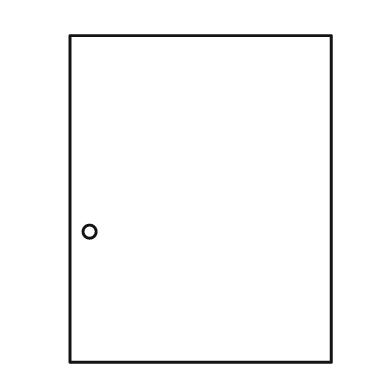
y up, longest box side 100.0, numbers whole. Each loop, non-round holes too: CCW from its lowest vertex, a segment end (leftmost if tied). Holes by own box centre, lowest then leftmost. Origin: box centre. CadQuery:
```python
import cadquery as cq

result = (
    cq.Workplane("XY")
    .moveTo(-40.0, -50.0)
    .lineTo(40.0, -50.0)
    .lineTo(40.0, 50.0)
    .lineTo(-40.0, 50.0)
    .close()
    .moveTo(-34.0, -10.0)
    .circle(2.0)
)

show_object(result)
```